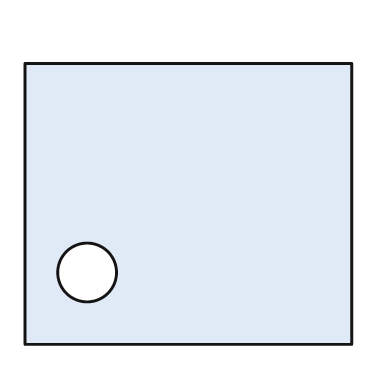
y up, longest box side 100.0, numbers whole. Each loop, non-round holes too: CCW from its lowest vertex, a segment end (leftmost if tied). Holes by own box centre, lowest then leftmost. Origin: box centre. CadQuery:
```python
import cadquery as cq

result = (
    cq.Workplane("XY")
    .moveTo(-50.0, -43.0)
    .lineTo(50.0, -43.0)
    .lineTo(50.0, 43.0)
    .lineTo(-50.0, 43.0)
    .close()
    .moveTo(-31.0, -21.0)
    .circle(9.0)
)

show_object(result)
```